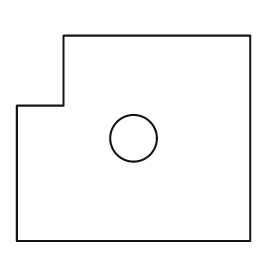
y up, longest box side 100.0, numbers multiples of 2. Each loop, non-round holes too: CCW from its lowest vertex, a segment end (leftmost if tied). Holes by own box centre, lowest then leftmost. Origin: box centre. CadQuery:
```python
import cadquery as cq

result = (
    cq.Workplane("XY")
    .moveTo(-50.0, -44.0)
    .lineTo(50.0, -44.0)
    .lineTo(50.0, 44.0)
    .lineTo(-30.0, 44.0)
    .lineTo(-30.0, 14.0)
    .lineTo(-50.0, 14.0)
    .close()
    .moveTo(0.0, 0.0)
    .circle(10.0)
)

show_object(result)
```